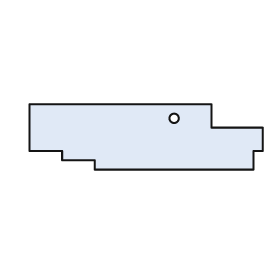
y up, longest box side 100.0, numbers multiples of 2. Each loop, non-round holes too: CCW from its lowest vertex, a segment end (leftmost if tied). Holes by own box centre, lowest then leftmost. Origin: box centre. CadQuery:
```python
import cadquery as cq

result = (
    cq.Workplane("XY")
    .moveTo(-22.0, -14.0)
    .lineTo(46.0, -14.0)
    .lineTo(46.0, -6.0)
    .lineTo(50.0, -6.0)
    .lineTo(50.0, 4.0)
    .lineTo(28.0, 4.0)
    .lineTo(28.0, 14.0)
    .lineTo(-50.0, 14.0)
    .lineTo(-50.0, -6.0)
    .lineTo(-36.0, -6.0)
    .lineTo(-36.0, -10.0)
    .lineTo(-22.0, -10.0)
    .close()
    .moveTo(12.0, 8.0)
    .circle(2.0)
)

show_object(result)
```